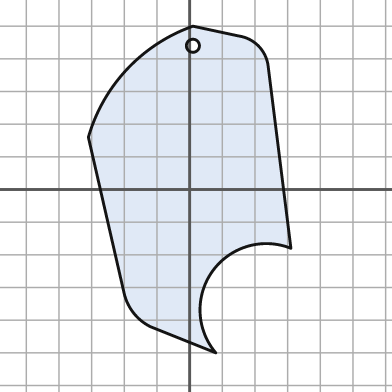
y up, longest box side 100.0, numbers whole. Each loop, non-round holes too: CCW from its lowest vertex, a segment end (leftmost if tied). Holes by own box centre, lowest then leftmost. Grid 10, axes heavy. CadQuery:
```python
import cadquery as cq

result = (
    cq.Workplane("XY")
    .moveTo(8.0, -50.0)
    .threePointArc((7.0, -25.0), (31.0, -18.0))
    .lineTo(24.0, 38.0)
    .threePointArc((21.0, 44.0), (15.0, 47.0))
    .lineTo(1.0, 50.0)
    .threePointArc((-19.0, 37.0), (-31.0, 16.0))
    .lineTo(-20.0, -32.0)
    .threePointArc((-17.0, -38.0), (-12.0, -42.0))
    .close()
    .moveTo(1.0, 44.0)
    .circle(2.0)
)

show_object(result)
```